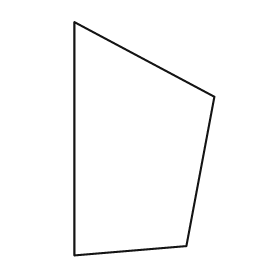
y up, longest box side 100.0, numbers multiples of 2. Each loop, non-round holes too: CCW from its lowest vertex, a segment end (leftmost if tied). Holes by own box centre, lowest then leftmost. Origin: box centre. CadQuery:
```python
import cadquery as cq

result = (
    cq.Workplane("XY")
    .moveTo(-30.0, -50.0)
    .lineTo(18.0, -46.0)
    .lineTo(30.0, 18.0)
    .lineTo(-30.0, 50.0)
    .close()
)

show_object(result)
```